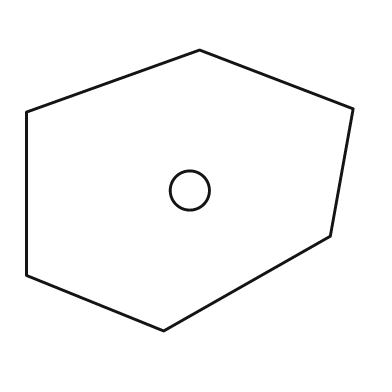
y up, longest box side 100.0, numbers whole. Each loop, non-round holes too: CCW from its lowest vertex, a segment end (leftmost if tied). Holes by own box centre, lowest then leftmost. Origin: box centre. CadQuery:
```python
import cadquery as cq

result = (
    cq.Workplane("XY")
    .moveTo(-8.0, -43.0)
    .lineTo(43.0, -14.0)
    .lineTo(50.0, 25.0)
    .lineTo(3.0, 43.0)
    .lineTo(-50.0, 24.0)
    .lineTo(-50.0, -26.0)
    .close()
    .moveTo(0.0, 0.0)
    .circle(6.0)
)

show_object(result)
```